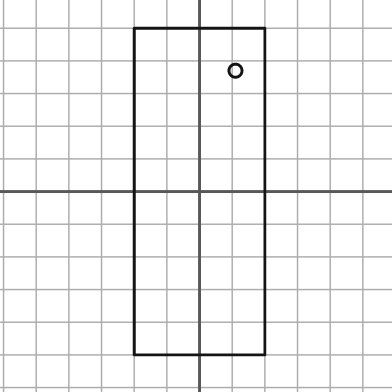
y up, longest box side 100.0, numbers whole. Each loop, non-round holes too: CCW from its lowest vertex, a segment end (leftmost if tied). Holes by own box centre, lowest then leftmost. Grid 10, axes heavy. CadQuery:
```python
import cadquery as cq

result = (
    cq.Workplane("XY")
    .moveTo(-20.0, -50.0)
    .lineTo(20.0, -50.0)
    .lineTo(20.0, 50.0)
    .lineTo(-20.0, 50.0)
    .close()
    .moveTo(11.0, 37.0)
    .circle(2.0)
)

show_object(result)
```